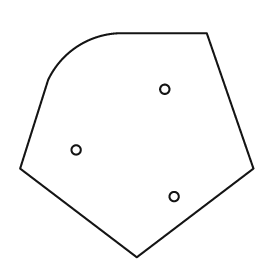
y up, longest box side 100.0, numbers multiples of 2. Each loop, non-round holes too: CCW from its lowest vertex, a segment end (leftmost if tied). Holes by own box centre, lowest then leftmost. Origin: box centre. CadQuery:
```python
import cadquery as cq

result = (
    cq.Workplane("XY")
    .moveTo(0.0, -48.0)
    .lineTo(50.0, -10.0)
    .lineTo(30.0, 48.0)
    .lineTo(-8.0, 48.0)
    .threePointArc((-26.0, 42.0), (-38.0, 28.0))
    .lineTo(-50.0, -10.0)
    .close()
    .moveTo(16.0, -22.0)
    .circle(2.0)
    .moveTo(-26.0, -2.0)
    .circle(2.0)
    .moveTo(12.0, 24.0)
    .circle(2.0)
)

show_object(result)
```